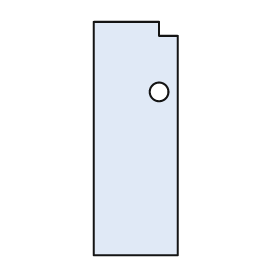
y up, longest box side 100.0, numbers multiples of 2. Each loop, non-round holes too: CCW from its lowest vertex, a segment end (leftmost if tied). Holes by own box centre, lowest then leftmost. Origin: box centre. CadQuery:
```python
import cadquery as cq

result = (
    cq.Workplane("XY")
    .moveTo(-18.0, -50.0)
    .lineTo(18.0, -50.0)
    .lineTo(18.0, 44.0)
    .lineTo(10.0, 44.0)
    .lineTo(10.0, 50.0)
    .lineTo(-18.0, 50.0)
    .close()
    .moveTo(10.0, 20.0)
    .circle(4.0)
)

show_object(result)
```